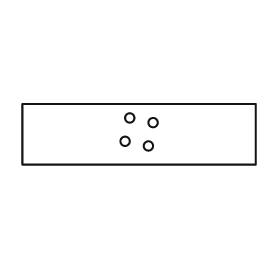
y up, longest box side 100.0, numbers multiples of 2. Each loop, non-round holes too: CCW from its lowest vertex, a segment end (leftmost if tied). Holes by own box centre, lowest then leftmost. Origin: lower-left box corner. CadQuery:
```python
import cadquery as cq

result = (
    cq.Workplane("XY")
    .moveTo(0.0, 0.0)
    .lineTo(100.0, 0.0)
    .lineTo(100.0, 26.0)
    .lineTo(0.0, 26.0)
    .close()
    .moveTo(54.0, 8.0)
    .circle(2.0)
    .moveTo(44.0, 10.0)
    .circle(2.0)
    .moveTo(56.0, 18.0)
    .circle(2.0)
    .moveTo(46.0, 20.0)
    .circle(2.0)
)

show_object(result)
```